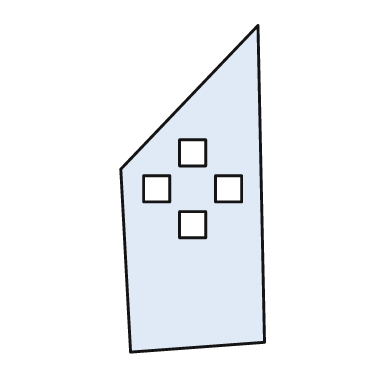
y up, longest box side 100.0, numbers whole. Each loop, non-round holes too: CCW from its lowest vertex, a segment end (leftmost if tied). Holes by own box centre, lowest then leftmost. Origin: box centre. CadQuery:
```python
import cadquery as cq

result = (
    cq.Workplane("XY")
    .moveTo(-19.0, -50.0)
    .lineTo(22.0, -47.0)
    .lineTo(20.0, 50.0)
    .lineTo(-22.0, 6.0)
    .close()
    .moveTo(-4.0, -15.0)
    .lineTo(4.0, -15.0)
    .lineTo(4.0, -7.0)
    .lineTo(-4.0, -7.0)
    .close()
    .moveTo(-15.0, -4.0)
    .lineTo(-7.0, -4.0)
    .lineTo(-7.0, 4.0)
    .lineTo(-15.0, 4.0)
    .close()
    .moveTo(7.0, -4.0)
    .lineTo(15.0, -4.0)
    .lineTo(15.0, 4.0)
    .lineTo(7.0, 4.0)
    .close()
    .moveTo(-4.0, 7.0)
    .lineTo(4.0, 7.0)
    .lineTo(4.0, 15.0)
    .lineTo(-4.0, 15.0)
    .close()
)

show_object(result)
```